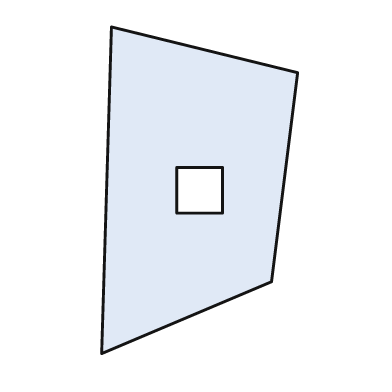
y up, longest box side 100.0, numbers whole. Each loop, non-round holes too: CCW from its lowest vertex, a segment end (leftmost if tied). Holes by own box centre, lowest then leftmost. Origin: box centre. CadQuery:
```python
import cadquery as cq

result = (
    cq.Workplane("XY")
    .moveTo(-30.0, -50.0)
    .lineTo(22.0, -28.0)
    .lineTo(30.0, 36.0)
    .lineTo(-27.0, 50.0)
    .close()
    .moveTo(-7.0, -7.0)
    .lineTo(7.0, -7.0)
    .lineTo(7.0, 7.0)
    .lineTo(-7.0, 7.0)
    .close()
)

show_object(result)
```